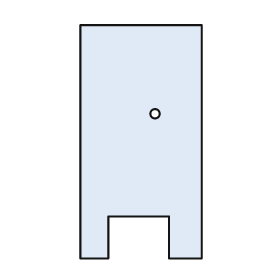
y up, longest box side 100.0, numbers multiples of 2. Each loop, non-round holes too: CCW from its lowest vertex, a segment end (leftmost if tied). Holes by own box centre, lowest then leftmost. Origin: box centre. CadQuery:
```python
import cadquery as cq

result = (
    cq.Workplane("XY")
    .moveTo(-26.0, -50.0)
    .lineTo(-14.0, -50.0)
    .lineTo(-14.0, -32.0)
    .lineTo(12.0, -32.0)
    .lineTo(12.0, -50.0)
    .lineTo(26.0, -50.0)
    .lineTo(26.0, 50.0)
    .lineTo(-26.0, 50.0)
    .close()
    .moveTo(6.0, 12.0)
    .circle(2.0)
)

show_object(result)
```